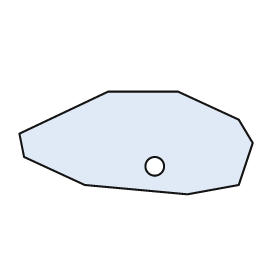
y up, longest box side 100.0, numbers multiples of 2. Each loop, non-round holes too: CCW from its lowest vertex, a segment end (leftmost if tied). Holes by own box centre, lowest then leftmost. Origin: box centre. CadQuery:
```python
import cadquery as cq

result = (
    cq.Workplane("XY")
    .moveTo(22.0, -22.0)
    .lineTo(44.0, -18.0)
    .lineTo(50.0, 0.0)
    .lineTo(44.0, 10.0)
    .lineTo(18.0, 22.0)
    .lineTo(-12.0, 22.0)
    .lineTo(-50.0, 4.0)
    .lineTo(-48.0, -6.0)
    .lineTo(-22.0, -18.0)
    .close()
    .moveTo(8.0, -10.0)
    .circle(4.0)
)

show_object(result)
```